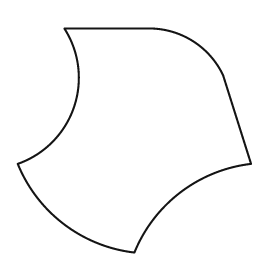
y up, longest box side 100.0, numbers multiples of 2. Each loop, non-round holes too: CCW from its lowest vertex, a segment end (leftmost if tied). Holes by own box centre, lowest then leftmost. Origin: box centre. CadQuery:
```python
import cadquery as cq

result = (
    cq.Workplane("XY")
    .moveTo(0.0, -48.0)
    .threePointArc((20.0, -22.0), (50.0, -10.0))
    .lineTo(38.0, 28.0)
    .threePointArc((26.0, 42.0), (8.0, 48.0))
    .lineTo(-30.0, 48.0)
    .threePointArc((-26.0, 14.0), (-50.0, -10.0))
    .threePointArc((-30.0, -36.0), (0.0, -48.0))
    .close()
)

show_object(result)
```